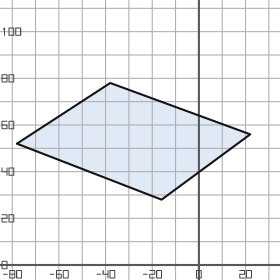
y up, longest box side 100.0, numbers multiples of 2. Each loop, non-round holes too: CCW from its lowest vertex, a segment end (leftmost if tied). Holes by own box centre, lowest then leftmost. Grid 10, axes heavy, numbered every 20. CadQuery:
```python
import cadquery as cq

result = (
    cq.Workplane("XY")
    .moveTo(-16.0, 28.0)
    .lineTo(22.0, 56.0)
    .lineTo(-38.0, 78.0)
    .lineTo(-78.0, 52.0)
    .close()
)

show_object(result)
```